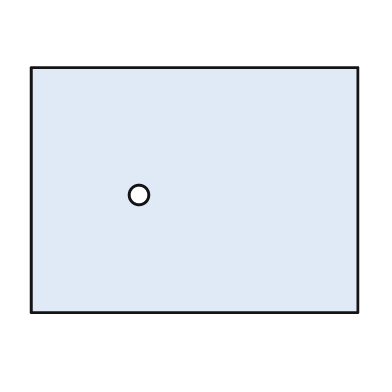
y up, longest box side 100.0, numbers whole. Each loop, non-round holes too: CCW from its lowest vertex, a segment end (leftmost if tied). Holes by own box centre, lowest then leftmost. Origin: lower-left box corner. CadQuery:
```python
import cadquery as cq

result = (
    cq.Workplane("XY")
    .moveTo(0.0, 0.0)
    .lineTo(100.0, 0.0)
    .lineTo(100.0, 75.0)
    .lineTo(0.0, 75.0)
    .close()
    .moveTo(33.0, 36.0)
    .circle(3.0)
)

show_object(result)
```